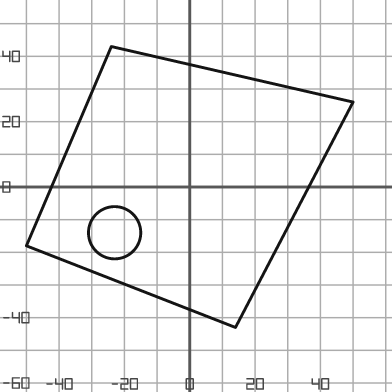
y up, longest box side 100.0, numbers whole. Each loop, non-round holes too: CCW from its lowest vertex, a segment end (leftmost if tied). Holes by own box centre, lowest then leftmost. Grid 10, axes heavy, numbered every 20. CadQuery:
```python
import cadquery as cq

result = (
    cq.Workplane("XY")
    .moveTo(14.0, -43.0)
    .lineTo(50.0, 26.0)
    .lineTo(-24.0, 43.0)
    .lineTo(-50.0, -18.0)
    .close()
    .moveTo(-23.0, -14.0)
    .circle(8.0)
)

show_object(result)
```